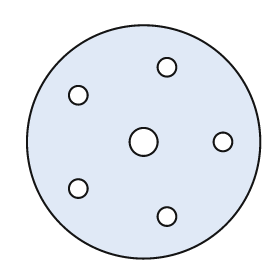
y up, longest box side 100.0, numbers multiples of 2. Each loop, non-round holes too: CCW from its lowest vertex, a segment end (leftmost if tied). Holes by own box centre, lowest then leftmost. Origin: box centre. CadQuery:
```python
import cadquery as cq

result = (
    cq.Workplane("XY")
    .moveTo(0.0, 0.0)
    .circle(50.0)
    .moveTo(10.0, -32.0)
    .circle(4.0)
    .moveTo(-28.0, -20.0)
    .circle(4.0)
    .moveTo(0.0, 0.0)
    .circle(6.0)
    .moveTo(34.0, 0.0)
    .circle(4.0)
    .moveTo(-28.0, 20.0)
    .circle(4.0)
    .moveTo(10.0, 32.0)
    .circle(4.0)
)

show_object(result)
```